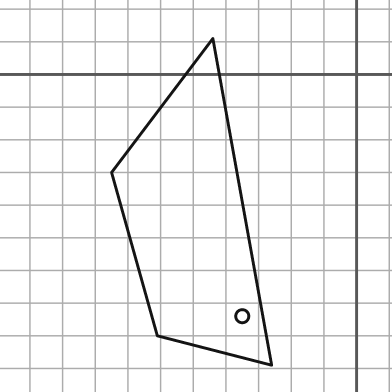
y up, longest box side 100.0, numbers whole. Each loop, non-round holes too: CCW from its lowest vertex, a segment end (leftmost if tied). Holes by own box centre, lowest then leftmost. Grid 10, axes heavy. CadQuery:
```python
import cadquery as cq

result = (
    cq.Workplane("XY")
    .moveTo(-26.0, -89.0)
    .lineTo(-44.0, 11.0)
    .lineTo(-75.0, -30.0)
    .lineTo(-61.0, -80.0)
    .close()
    .moveTo(-35.0, -74.0)
    .circle(2.0)
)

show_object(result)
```